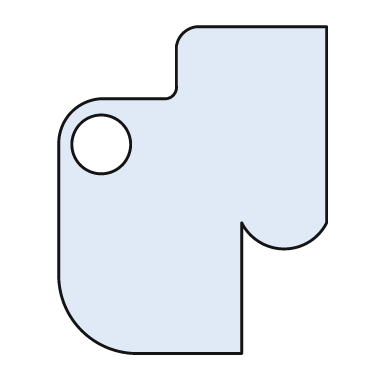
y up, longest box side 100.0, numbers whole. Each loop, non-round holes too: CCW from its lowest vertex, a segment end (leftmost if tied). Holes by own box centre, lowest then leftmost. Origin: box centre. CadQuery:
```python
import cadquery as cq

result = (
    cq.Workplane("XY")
    .moveTo(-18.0, -50.0)
    .lineTo(15.0, -50.0)
    .lineTo(15.0, -10.0)
    .threePointArc((28.0, -18.0), (41.0, -10.0))
    .lineTo(41.0, 50.0)
    .lineTo(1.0, 50.0)
    .threePointArc((-3.0, 48.0), (-5.0, 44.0))
    .lineTo(-5.0, 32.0)
    .threePointArc((-6.0, 29.0), (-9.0, 28.0))
    .lineTo(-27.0, 28.0)
    .threePointArc((-37.0, 24.0), (-41.0, 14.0))
    .lineTo(-41.0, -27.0)
    .threePointArc((-34.0, -43.0), (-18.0, -50.0))
    .close()
    .moveTo(-28.0, 14.0)
    .circle(9.0)
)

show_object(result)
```